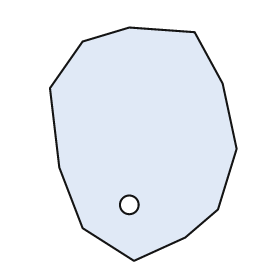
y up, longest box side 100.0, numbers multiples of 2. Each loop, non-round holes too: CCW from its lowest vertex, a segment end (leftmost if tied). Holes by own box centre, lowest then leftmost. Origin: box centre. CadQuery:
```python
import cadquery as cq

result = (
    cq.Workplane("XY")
    .moveTo(-4.0, -50.0)
    .lineTo(18.0, -40.0)
    .lineTo(32.0, -28.0)
    .lineTo(40.0, -2.0)
    .lineTo(34.0, 26.0)
    .lineTo(22.0, 48.0)
    .lineTo(-6.0, 50.0)
    .lineTo(-26.0, 44.0)
    .lineTo(-40.0, 24.0)
    .lineTo(-36.0, -10.0)
    .lineTo(-26.0, -36.0)
    .close()
    .moveTo(-6.0, -26.0)
    .circle(4.0)
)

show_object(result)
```